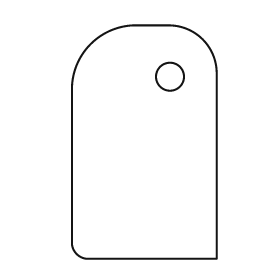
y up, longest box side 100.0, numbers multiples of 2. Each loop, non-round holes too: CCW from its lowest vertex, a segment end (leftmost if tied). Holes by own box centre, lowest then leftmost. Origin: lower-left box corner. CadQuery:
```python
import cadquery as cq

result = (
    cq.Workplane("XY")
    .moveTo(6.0, 0.0)
    .lineTo(62.0, 0.0)
    .lineTo(62.0, 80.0)
    .threePointArc((56.0, 94.0), (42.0, 100.0))
    .lineTo(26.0, 100.0)
    .threePointArc((8.0, 92.0), (0.0, 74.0))
    .lineTo(0.0, 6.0)
    .threePointArc((2.0, 2.0), (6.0, 0.0))
    .close()
    .moveTo(42.0, 78.0)
    .circle(6.0)
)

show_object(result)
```